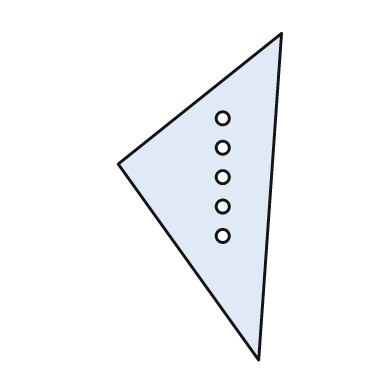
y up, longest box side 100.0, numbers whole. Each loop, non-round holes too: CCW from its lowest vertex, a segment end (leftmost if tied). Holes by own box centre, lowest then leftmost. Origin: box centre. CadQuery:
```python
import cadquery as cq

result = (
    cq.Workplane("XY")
    .moveTo(18.0, -50.0)
    .lineTo(25.0, 50.0)
    .lineTo(-25.0, 10.0)
    .close()
    .moveTo(7.0, -12.0)
    .circle(2.0)
    .moveTo(7.0, -3.0)
    .circle(2.0)
    .moveTo(7.0, 6.0)
    .circle(2.0)
    .moveTo(7.0, 15.0)
    .circle(2.0)
    .moveTo(7.0, 24.0)
    .circle(2.0)
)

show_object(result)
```